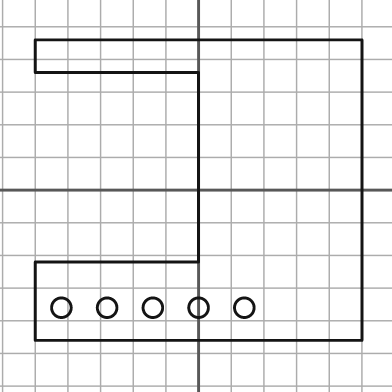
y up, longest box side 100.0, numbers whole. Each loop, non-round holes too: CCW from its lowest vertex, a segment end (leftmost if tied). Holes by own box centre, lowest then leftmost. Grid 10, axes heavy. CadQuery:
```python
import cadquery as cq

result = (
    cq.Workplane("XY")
    .moveTo(-50.0, -46.0)
    .lineTo(50.0, -46.0)
    .lineTo(50.0, 46.0)
    .lineTo(-50.0, 46.0)
    .lineTo(-50.0, 36.0)
    .lineTo(0.0, 36.0)
    .lineTo(0.0, -22.0)
    .lineTo(-50.0, -22.0)
    .close()
    .moveTo(-42.0, -36.0)
    .circle(3.0)
    .moveTo(-28.0, -36.0)
    .circle(3.0)
    .moveTo(-14.0, -36.0)
    .circle(3.0)
    .moveTo(0.0, -36.0)
    .circle(3.0)
    .moveTo(14.0, -36.0)
    .circle(3.0)
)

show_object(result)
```